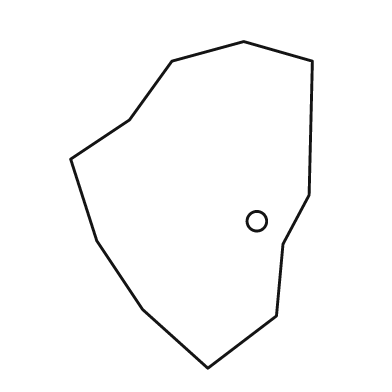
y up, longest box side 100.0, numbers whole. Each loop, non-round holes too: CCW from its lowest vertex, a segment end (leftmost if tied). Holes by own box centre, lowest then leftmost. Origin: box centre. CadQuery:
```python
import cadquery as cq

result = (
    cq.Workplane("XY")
    .moveTo(5.0, -50.0)
    .lineTo(26.0, -34.0)
    .lineTo(28.0, -12.0)
    .lineTo(36.0, 3.0)
    .lineTo(37.0, 44.0)
    .lineTo(16.0, 50.0)
    .lineTo(-6.0, 44.0)
    .lineTo(-19.0, 26.0)
    .lineTo(-37.0, 14.0)
    .lineTo(-29.0, -11.0)
    .lineTo(-15.0, -32.0)
    .close()
    .moveTo(20.0, -5.0)
    .circle(3.0)
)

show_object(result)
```